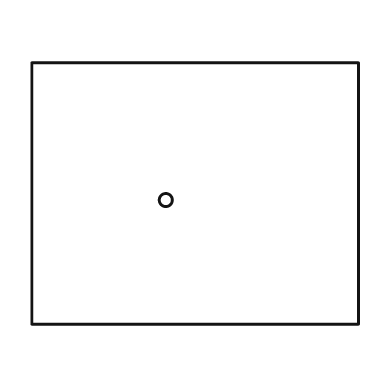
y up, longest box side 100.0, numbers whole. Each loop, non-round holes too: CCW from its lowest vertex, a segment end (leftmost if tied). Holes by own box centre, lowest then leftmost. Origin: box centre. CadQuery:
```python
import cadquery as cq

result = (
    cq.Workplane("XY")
    .moveTo(-50.0, -40.0)
    .lineTo(50.0, -40.0)
    .lineTo(50.0, 40.0)
    .lineTo(-50.0, 40.0)
    .close()
    .moveTo(-9.0, -2.0)
    .circle(2.0)
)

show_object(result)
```